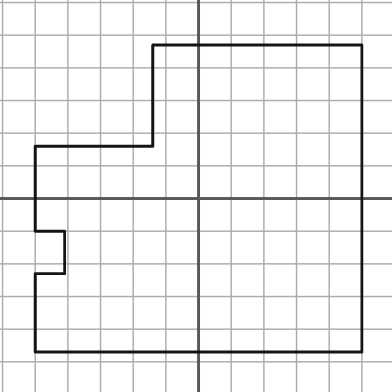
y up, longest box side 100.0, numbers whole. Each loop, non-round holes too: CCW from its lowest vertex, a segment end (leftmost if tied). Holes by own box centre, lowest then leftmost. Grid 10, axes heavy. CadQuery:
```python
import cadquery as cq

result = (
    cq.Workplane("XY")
    .moveTo(-50.0, -47.0)
    .lineTo(50.0, -47.0)
    .lineTo(50.0, 47.0)
    .lineTo(-14.0, 47.0)
    .lineTo(-14.0, 16.0)
    .lineTo(-50.0, 16.0)
    .lineTo(-50.0, -10.0)
    .lineTo(-41.0, -10.0)
    .lineTo(-41.0, -23.0)
    .lineTo(-50.0, -23.0)
    .close()
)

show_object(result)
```